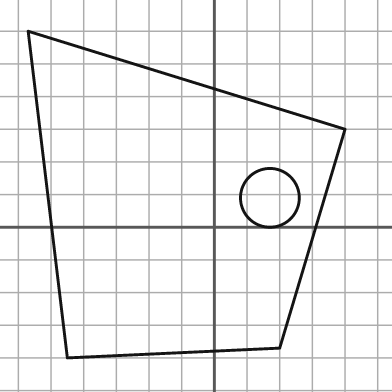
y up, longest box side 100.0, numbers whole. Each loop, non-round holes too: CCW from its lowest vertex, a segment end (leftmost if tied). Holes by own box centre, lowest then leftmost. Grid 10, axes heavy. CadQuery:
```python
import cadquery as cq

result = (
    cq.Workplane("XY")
    .moveTo(-45.0, -40.0)
    .lineTo(20.0, -37.0)
    .lineTo(40.0, 30.0)
    .lineTo(-57.0, 60.0)
    .close()
    .moveTo(17.0, 9.0)
    .circle(9.0)
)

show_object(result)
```